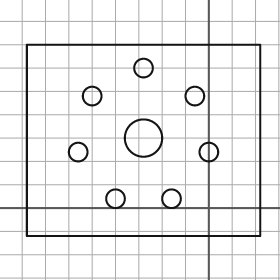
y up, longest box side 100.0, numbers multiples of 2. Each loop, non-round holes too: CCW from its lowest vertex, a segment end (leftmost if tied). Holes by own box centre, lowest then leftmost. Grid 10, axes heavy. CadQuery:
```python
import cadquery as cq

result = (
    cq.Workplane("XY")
    .moveTo(-78.0, -12.0)
    .lineTo(22.0, -12.0)
    .lineTo(22.0, 70.0)
    .lineTo(-78.0, 70.0)
    .close()
    .moveTo(-40.0, 4.0)
    .circle(4.0)
    .moveTo(-16.0, 4.0)
    .circle(4.0)
    .moveTo(-56.0, 24.0)
    .circle(4.0)
    .moveTo(0.0, 24.0)
    .circle(4.0)
    .moveTo(-28.0, 30.0)
    .circle(8.0)
    .moveTo(-50.0, 48.0)
    .circle(4.0)
    .moveTo(-6.0, 48.0)
    .circle(4.0)
    .moveTo(-28.0, 60.0)
    .circle(4.0)
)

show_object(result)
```